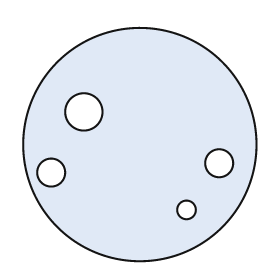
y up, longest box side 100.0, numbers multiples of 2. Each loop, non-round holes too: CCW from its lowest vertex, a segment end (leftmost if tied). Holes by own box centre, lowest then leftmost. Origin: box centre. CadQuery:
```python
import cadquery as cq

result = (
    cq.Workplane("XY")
    .moveTo(0.0, 0.0)
    .circle(50.0)
    .moveTo(20.0, -28.0)
    .circle(4.0)
    .moveTo(-38.0, -12.0)
    .circle(6.0)
    .moveTo(34.0, -8.0)
    .circle(6.0)
    .moveTo(-24.0, 14.0)
    .circle(8.0)
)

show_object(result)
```